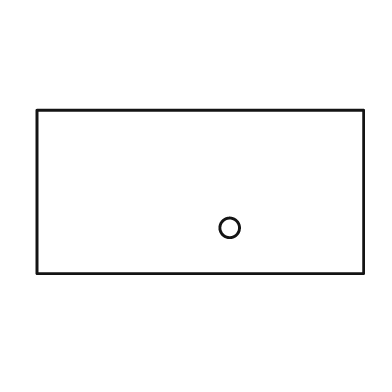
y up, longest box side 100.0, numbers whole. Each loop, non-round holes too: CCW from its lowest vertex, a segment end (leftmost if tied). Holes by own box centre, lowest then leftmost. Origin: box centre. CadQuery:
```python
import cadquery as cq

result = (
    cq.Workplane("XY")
    .moveTo(-50.0, -25.0)
    .lineTo(50.0, -25.0)
    .lineTo(50.0, 25.0)
    .lineTo(-50.0, 25.0)
    .close()
    .moveTo(9.0, -11.0)
    .circle(3.0)
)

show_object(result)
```